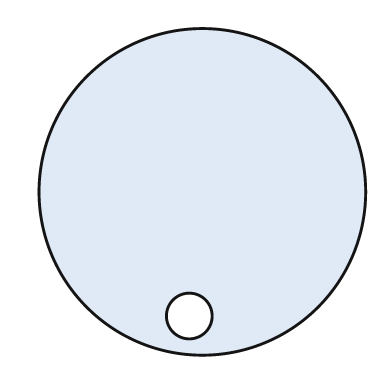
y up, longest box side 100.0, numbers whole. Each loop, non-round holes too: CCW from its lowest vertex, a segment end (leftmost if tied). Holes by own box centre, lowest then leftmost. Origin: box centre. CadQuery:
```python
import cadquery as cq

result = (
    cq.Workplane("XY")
    .moveTo(0.0, 0.0)
    .circle(50.0)
    .moveTo(-4.0, -38.0)
    .circle(7.0)
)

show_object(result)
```